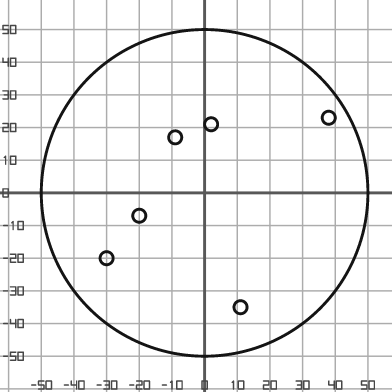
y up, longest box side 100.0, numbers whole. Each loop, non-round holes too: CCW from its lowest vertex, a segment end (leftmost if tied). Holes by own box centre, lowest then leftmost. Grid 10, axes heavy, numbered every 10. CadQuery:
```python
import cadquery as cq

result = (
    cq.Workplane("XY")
    .moveTo(0.0, 0.0)
    .circle(50.0)
    .moveTo(11.0, -35.0)
    .circle(2.0)
    .moveTo(-30.0, -20.0)
    .circle(2.0)
    .moveTo(-20.0, -7.0)
    .circle(2.0)
    .moveTo(-9.0, 17.0)
    .circle(2.0)
    .moveTo(2.0, 21.0)
    .circle(2.0)
    .moveTo(38.0, 23.0)
    .circle(2.0)
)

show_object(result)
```